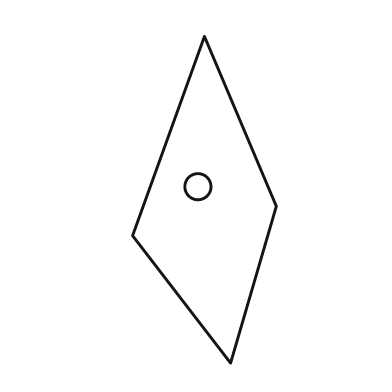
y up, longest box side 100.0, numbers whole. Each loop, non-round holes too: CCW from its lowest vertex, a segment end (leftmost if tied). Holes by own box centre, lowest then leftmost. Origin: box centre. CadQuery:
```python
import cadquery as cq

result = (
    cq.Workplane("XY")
    .moveTo(8.0, -50.0)
    .lineTo(22.0, -2.0)
    .lineTo(0.0, 50.0)
    .lineTo(-22.0, -11.0)
    .close()
    .moveTo(-2.0, 4.0)
    .circle(4.0)
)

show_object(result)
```